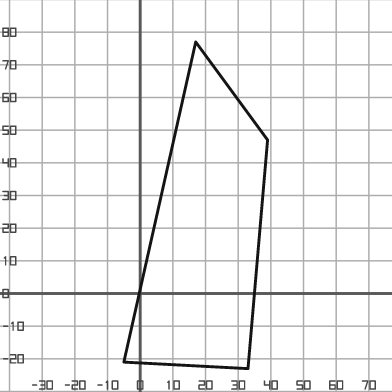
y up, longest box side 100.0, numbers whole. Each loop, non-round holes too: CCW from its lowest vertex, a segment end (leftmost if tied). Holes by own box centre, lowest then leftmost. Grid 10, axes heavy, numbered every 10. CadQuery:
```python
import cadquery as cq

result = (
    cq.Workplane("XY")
    .moveTo(33.0, -23.0)
    .lineTo(39.0, 47.0)
    .lineTo(17.0, 77.0)
    .lineTo(-5.0, -21.0)
    .close()
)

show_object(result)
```